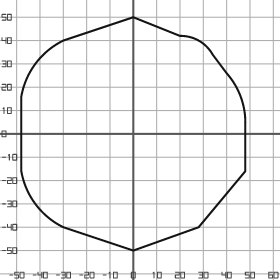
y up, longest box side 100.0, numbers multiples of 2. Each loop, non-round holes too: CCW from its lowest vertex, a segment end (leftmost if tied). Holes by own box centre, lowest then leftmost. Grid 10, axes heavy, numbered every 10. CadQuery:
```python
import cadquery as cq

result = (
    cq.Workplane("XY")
    .moveTo(0.0, -50.0)
    .lineTo(28.0, -40.0)
    .lineTo(48.0, -16.0)
    .lineTo(48.0, 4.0)
    .threePointArc((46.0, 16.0), (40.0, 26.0))
    .lineTo(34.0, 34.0)
    .threePointArc((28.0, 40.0), (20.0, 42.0))
    .lineTo(0.0, 50.0)
    .lineTo(-30.0, 40.0)
    .threePointArc((-42.0, 30.0), (-48.0, 16.0))
    .lineTo(-48.0, -16.0)
    .threePointArc((-42.0, -30.0), (-30.0, -40.0))
    .close()
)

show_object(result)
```